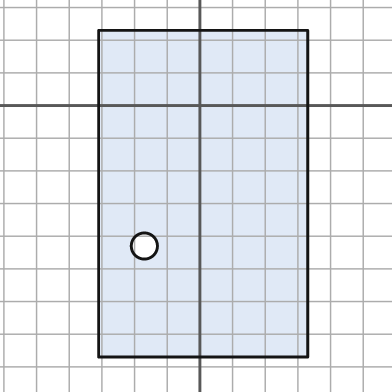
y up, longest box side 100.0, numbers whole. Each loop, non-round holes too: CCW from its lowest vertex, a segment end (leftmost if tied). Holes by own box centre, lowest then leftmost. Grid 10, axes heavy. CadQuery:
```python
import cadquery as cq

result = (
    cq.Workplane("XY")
    .moveTo(-31.0, -77.0)
    .lineTo(33.0, -77.0)
    .lineTo(33.0, 23.0)
    .lineTo(-31.0, 23.0)
    .close()
    .moveTo(-17.0, -43.0)
    .circle(4.0)
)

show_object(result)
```